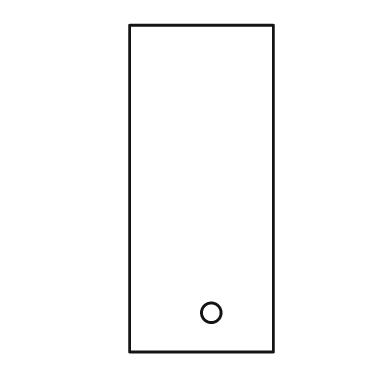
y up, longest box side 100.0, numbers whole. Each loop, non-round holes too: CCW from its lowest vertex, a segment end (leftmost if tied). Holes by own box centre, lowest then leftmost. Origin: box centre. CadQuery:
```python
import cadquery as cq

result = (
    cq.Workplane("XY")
    .moveTo(-22.0, -50.0)
    .lineTo(22.0, -50.0)
    .lineTo(22.0, 50.0)
    .lineTo(-22.0, 50.0)
    .close()
    .moveTo(3.0, -38.0)
    .circle(3.0)
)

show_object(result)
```